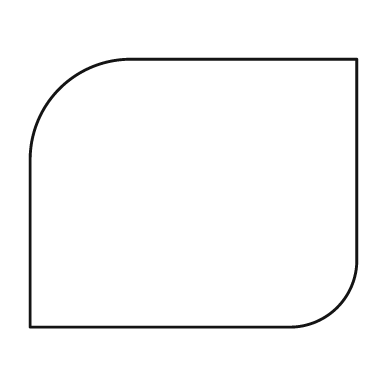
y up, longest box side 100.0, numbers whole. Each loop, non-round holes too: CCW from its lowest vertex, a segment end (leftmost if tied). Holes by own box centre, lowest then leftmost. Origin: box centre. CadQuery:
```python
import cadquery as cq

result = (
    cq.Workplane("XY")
    .moveTo(-50.0, -41.0)
    .lineTo(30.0, -41.0)
    .threePointArc((44.0, -35.0), (50.0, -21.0))
    .lineTo(50.0, 41.0)
    .lineTo(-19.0, 41.0)
    .threePointArc((-41.0, 32.0), (-50.0, 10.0))
    .close()
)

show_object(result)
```